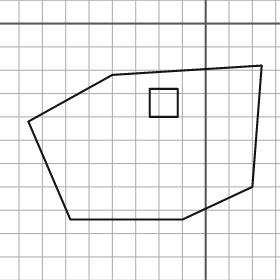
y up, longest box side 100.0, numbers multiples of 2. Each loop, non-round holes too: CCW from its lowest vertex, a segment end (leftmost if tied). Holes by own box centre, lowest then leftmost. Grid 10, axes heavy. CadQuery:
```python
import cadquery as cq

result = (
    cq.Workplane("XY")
    .moveTo(-58.0, -84.0)
    .lineTo(-10.0, -84.0)
    .lineTo(20.0, -70.0)
    .lineTo(24.0, -18.0)
    .lineTo(-40.0, -22.0)
    .lineTo(-76.0, -42.0)
    .close()
    .moveTo(-24.0, -40.0)
    .lineTo(-12.0, -40.0)
    .lineTo(-12.0, -28.0)
    .lineTo(-24.0, -28.0)
    .close()
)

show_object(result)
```